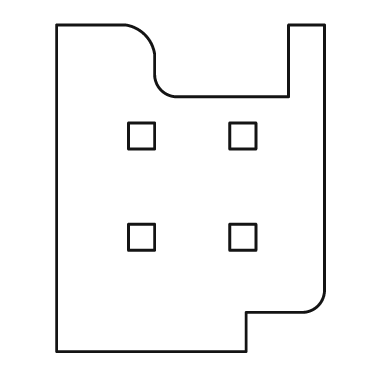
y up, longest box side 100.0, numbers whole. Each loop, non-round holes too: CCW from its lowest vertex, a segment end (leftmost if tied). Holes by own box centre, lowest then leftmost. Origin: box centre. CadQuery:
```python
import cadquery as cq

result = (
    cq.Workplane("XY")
    .moveTo(-41.0, -50.0)
    .lineTo(17.0, -50.0)
    .lineTo(17.0, -38.0)
    .lineTo(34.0, -38.0)
    .threePointArc((39.0, -36.0), (41.0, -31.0))
    .lineTo(41.0, 50.0)
    .lineTo(30.0, 50.0)
    .lineTo(30.0, 28.0)
    .lineTo(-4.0, 28.0)
    .threePointArc((-9.0, 30.0), (-11.0, 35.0))
    .lineTo(-11.0, 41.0)
    .threePointArc((-14.0, 47.0), (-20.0, 50.0))
    .lineTo(-41.0, 50.0)
    .close()
    .moveTo(-19.0, -19.0)
    .lineTo(-11.0, -19.0)
    .lineTo(-11.0, -11.0)
    .lineTo(-19.0, -11.0)
    .close()
    .moveTo(12.0, -19.0)
    .lineTo(20.0, -19.0)
    .lineTo(20.0, -11.0)
    .lineTo(12.0, -11.0)
    .close()
    .moveTo(-19.0, 12.0)
    .lineTo(-11.0, 12.0)
    .lineTo(-11.0, 20.0)
    .lineTo(-19.0, 20.0)
    .close()
    .moveTo(12.0, 12.0)
    .lineTo(20.0, 12.0)
    .lineTo(20.0, 20.0)
    .lineTo(12.0, 20.0)
    .close()
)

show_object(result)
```